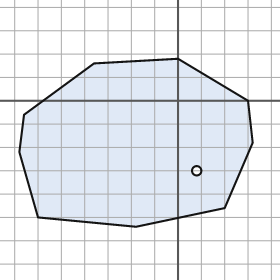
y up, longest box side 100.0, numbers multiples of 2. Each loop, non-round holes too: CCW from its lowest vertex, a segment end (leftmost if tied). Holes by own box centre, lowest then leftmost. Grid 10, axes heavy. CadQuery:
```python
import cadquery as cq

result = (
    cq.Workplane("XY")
    .moveTo(-18.0, -54.0)
    .lineTo(20.0, -46.0)
    .lineTo(32.0, -18.0)
    .lineTo(30.0, 0.0)
    .lineTo(0.0, 18.0)
    .lineTo(-36.0, 16.0)
    .lineTo(-66.0, -6.0)
    .lineTo(-68.0, -22.0)
    .lineTo(-60.0, -50.0)
    .close()
    .moveTo(8.0, -30.0)
    .circle(2.0)
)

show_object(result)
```